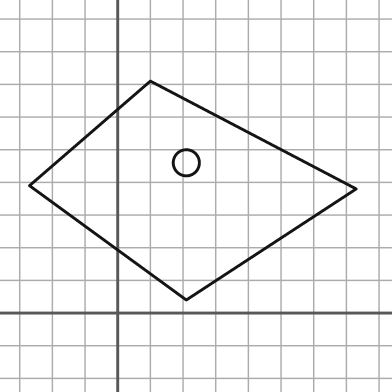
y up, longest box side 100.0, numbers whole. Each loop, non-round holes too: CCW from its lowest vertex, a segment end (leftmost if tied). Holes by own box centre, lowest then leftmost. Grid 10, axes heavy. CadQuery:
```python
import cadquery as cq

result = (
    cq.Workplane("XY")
    .moveTo(21.0, 4.0)
    .lineTo(73.0, 38.0)
    .lineTo(10.0, 71.0)
    .lineTo(-27.0, 39.0)
    .close()
    .moveTo(21.0, 46.0)
    .circle(4.0)
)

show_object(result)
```